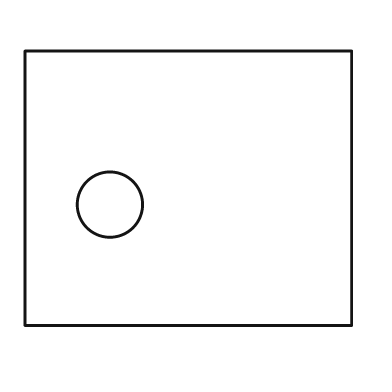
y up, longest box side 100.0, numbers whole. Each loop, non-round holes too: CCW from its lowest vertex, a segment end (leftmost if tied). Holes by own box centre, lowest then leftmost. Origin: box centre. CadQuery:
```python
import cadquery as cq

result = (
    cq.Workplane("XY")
    .moveTo(-50.0, -42.0)
    .lineTo(50.0, -42.0)
    .lineTo(50.0, 42.0)
    .lineTo(-50.0, 42.0)
    .close()
    .moveTo(-24.0, -5.0)
    .circle(10.0)
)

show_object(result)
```